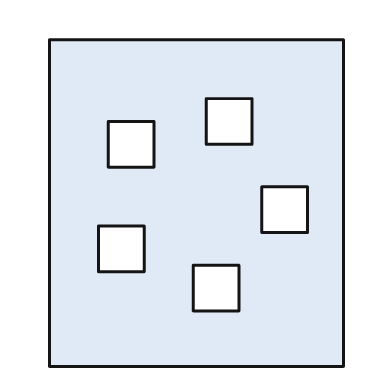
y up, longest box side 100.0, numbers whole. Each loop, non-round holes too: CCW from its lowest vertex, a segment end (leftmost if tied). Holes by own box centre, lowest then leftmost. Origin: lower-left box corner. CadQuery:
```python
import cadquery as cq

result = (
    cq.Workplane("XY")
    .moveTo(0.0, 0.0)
    .lineTo(90.0, 0.0)
    .lineTo(90.0, 100.0)
    .lineTo(0.0, 100.0)
    .close()
    .moveTo(44.0, 17.0)
    .lineTo(58.0, 17.0)
    .lineTo(58.0, 31.0)
    .lineTo(44.0, 31.0)
    .close()
    .moveTo(15.0, 29.0)
    .lineTo(29.0, 29.0)
    .lineTo(29.0, 43.0)
    .lineTo(15.0, 43.0)
    .close()
    .moveTo(65.0, 41.0)
    .lineTo(79.0, 41.0)
    .lineTo(79.0, 55.0)
    .lineTo(65.0, 55.0)
    .close()
    .moveTo(18.0, 61.0)
    .lineTo(32.0, 61.0)
    .lineTo(32.0, 75.0)
    .lineTo(18.0, 75.0)
    .close()
    .moveTo(48.0, 68.0)
    .lineTo(62.0, 68.0)
    .lineTo(62.0, 82.0)
    .lineTo(48.0, 82.0)
    .close()
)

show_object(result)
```